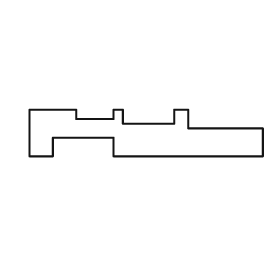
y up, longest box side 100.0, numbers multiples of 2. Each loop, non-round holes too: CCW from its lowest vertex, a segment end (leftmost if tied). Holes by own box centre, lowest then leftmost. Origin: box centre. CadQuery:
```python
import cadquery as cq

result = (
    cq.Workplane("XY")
    .moveTo(-50.0, -10.0)
    .lineTo(-40.0, -10.0)
    .lineTo(-40.0, -2.0)
    .lineTo(-14.0, -2.0)
    .lineTo(-14.0, -10.0)
    .lineTo(50.0, -10.0)
    .lineTo(50.0, 2.0)
    .lineTo(18.0, 2.0)
    .lineTo(18.0, 10.0)
    .lineTo(12.0, 10.0)
    .lineTo(12.0, 4.0)
    .lineTo(-10.0, 4.0)
    .lineTo(-10.0, 10.0)
    .lineTo(-14.0, 10.0)
    .lineTo(-14.0, 6.0)
    .lineTo(-30.0, 6.0)
    .lineTo(-30.0, 10.0)
    .lineTo(-50.0, 10.0)
    .close()
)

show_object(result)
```